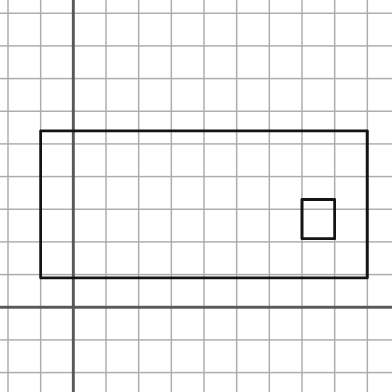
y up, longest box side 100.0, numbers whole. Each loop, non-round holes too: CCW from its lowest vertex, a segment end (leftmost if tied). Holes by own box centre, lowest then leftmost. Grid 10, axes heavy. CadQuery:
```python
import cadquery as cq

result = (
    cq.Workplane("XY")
    .moveTo(-10.0, 9.0)
    .lineTo(90.0, 9.0)
    .lineTo(90.0, 54.0)
    .lineTo(-10.0, 54.0)
    .close()
    .moveTo(70.0, 21.0)
    .lineTo(80.0, 21.0)
    .lineTo(80.0, 33.0)
    .lineTo(70.0, 33.0)
    .close()
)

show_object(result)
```